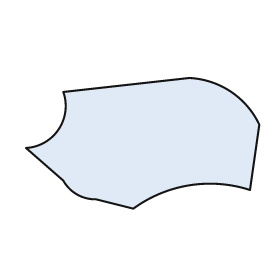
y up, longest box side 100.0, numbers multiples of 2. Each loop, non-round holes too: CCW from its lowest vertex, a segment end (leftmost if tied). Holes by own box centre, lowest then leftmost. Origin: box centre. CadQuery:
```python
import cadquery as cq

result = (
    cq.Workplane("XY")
    .moveTo(-4.0, -28.0)
    .threePointArc((20.0, -18.0), (46.0, -20.0))
    .lineTo(50.0, 8.0)
    .threePointArc((38.0, 22.0), (20.0, 28.0))
    .lineTo(-34.0, 22.0)
    .threePointArc((-36.0, 6.0), (-50.0, -2.0))
    .lineTo(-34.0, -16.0)
    .threePointArc((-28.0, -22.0), (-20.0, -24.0))
    .close()
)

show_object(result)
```